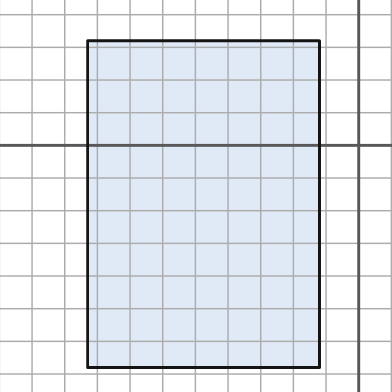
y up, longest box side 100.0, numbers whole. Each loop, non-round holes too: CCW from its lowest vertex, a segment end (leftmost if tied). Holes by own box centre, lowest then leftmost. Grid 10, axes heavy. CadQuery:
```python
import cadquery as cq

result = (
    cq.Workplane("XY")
    .moveTo(-83.0, -68.0)
    .lineTo(-12.0, -68.0)
    .lineTo(-12.0, 32.0)
    .lineTo(-83.0, 32.0)
    .close()
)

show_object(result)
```